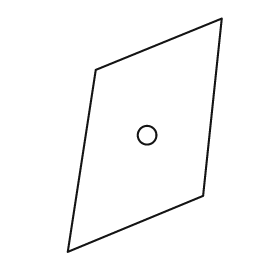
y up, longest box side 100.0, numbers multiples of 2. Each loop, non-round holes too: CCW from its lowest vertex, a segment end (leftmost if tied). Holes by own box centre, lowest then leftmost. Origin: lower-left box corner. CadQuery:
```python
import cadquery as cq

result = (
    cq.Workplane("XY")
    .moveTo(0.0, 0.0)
    .lineTo(58.0, 24.0)
    .lineTo(66.0, 100.0)
    .lineTo(12.0, 78.0)
    .close()
    .moveTo(34.0, 50.0)
    .circle(4.0)
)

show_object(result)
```